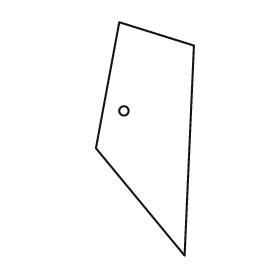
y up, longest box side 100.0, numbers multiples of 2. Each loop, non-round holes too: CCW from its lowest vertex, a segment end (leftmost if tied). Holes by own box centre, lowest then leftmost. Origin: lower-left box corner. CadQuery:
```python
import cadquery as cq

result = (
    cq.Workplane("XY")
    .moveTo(38.0, 0.0)
    .lineTo(42.0, 90.0)
    .lineTo(10.0, 100.0)
    .lineTo(0.0, 46.0)
    .close()
    .moveTo(12.0, 62.0)
    .circle(2.0)
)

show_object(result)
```